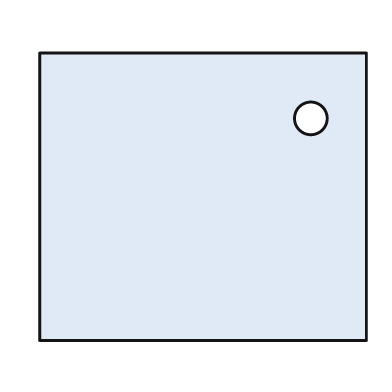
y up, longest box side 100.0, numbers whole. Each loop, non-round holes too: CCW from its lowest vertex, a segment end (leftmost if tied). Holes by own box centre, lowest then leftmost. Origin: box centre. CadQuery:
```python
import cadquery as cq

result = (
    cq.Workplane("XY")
    .moveTo(-50.0, -44.0)
    .lineTo(50.0, -44.0)
    .lineTo(50.0, 44.0)
    .lineTo(-50.0, 44.0)
    .close()
    .moveTo(33.0, 24.0)
    .circle(5.0)
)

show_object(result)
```